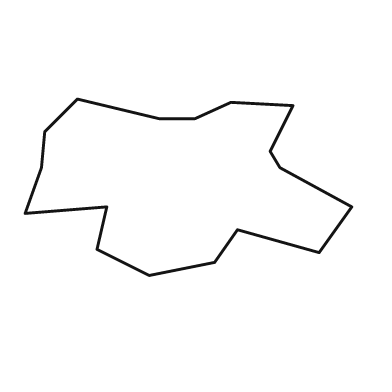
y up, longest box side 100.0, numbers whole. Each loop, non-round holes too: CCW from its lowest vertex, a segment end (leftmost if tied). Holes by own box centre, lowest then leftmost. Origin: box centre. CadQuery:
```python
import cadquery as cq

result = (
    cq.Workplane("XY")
    .moveTo(-12.0, -27.0)
    .lineTo(8.0, -23.0)
    .lineTo(15.0, -13.0)
    .lineTo(40.0, -20.0)
    .lineTo(50.0, -6.0)
    .lineTo(28.0, 6.0)
    .lineTo(25.0, 11.0)
    .lineTo(32.0, 25.0)
    .lineTo(13.0, 26.0)
    .lineTo(2.0, 21.0)
    .lineTo(-9.0, 21.0)
    .lineTo(-34.0, 27.0)
    .lineTo(-44.0, 17.0)
    .lineTo(-45.0, 6.0)
    .lineTo(-50.0, -8.0)
    .lineTo(-25.0, -6.0)
    .lineTo(-28.0, -19.0)
    .close()
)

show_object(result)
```